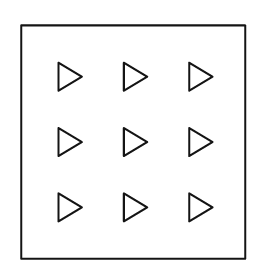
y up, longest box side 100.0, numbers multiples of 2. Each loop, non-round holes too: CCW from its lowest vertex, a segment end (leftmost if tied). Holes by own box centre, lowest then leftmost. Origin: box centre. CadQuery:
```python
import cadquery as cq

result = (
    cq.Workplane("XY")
    .moveTo(-48.0, -50.0)
    .lineTo(48.0, -50.0)
    .lineTo(48.0, 50.0)
    .lineTo(-48.0, 50.0)
    .close()
    .moveTo(-32.0, -34.0)
    .lineTo(-22.0, -28.0)
    .lineTo(-32.0, -22.0)
    .close()
    .moveTo(-4.0, -34.0)
    .lineTo(6.0, -28.0)
    .lineTo(-4.0, -22.0)
    .close()
    .moveTo(24.0, -34.0)
    .lineTo(34.0, -28.0)
    .lineTo(24.0, -22.0)
    .close()
    .moveTo(-32.0, -6.0)
    .lineTo(-22.0, 0.0)
    .lineTo(-32.0, 6.0)
    .close()
    .moveTo(-4.0, -6.0)
    .lineTo(6.0, 0.0)
    .lineTo(-4.0, 6.0)
    .close()
    .moveTo(24.0, -6.0)
    .lineTo(34.0, 0.0)
    .lineTo(24.0, 6.0)
    .close()
    .moveTo(-32.0, 22.0)
    .lineTo(-22.0, 28.0)
    .lineTo(-32.0, 34.0)
    .close()
    .moveTo(-4.0, 22.0)
    .lineTo(6.0, 28.0)
    .lineTo(-4.0, 34.0)
    .close()
    .moveTo(24.0, 22.0)
    .lineTo(34.0, 28.0)
    .lineTo(24.0, 34.0)
    .close()
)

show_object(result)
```